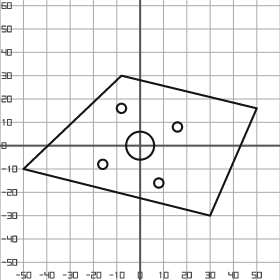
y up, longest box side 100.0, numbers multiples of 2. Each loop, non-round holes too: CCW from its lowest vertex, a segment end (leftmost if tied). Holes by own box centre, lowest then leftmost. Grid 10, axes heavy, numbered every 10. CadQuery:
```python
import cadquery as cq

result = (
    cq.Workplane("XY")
    .moveTo(30.0, -30.0)
    .lineTo(50.0, 16.0)
    .lineTo(-8.0, 30.0)
    .lineTo(-50.0, -10.0)
    .close()
    .moveTo(8.0, -16.0)
    .circle(2.0)
    .moveTo(-16.0, -8.0)
    .circle(2.0)
    .moveTo(0.0, 0.0)
    .circle(6.0)
    .moveTo(16.0, 8.0)
    .circle(2.0)
    .moveTo(-8.0, 16.0)
    .circle(2.0)
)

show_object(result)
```